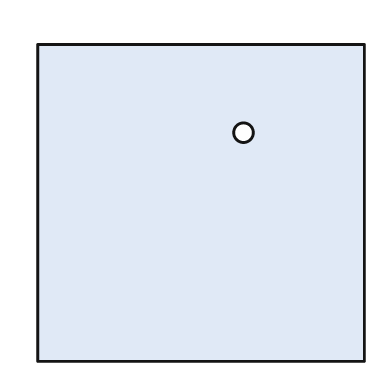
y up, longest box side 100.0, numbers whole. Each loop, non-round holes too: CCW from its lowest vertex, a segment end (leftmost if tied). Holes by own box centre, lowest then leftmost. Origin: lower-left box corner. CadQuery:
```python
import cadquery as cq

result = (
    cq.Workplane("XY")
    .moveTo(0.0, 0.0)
    .lineTo(100.0, 0.0)
    .lineTo(100.0, 97.0)
    .lineTo(0.0, 97.0)
    .close()
    .moveTo(63.0, 70.0)
    .circle(3.0)
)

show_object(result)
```